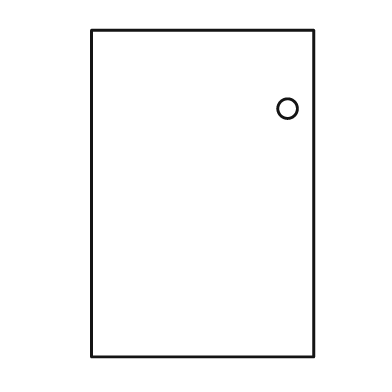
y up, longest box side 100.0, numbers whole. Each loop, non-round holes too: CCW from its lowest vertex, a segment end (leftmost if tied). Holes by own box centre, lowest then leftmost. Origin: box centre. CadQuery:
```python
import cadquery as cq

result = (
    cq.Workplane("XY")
    .moveTo(-34.0, -50.0)
    .lineTo(34.0, -50.0)
    .lineTo(34.0, 50.0)
    .lineTo(-34.0, 50.0)
    .close()
    .moveTo(26.0, 26.0)
    .circle(3.0)
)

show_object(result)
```